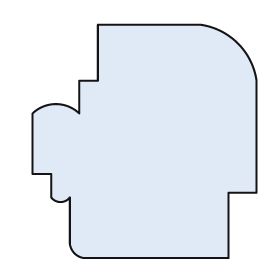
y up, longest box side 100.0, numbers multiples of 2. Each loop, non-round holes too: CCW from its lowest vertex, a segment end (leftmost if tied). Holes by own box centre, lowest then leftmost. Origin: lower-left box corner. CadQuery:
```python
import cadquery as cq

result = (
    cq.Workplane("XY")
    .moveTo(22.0, 0.0)
    .lineTo(84.0, 0.0)
    .lineTo(84.0, 28.0)
    .lineTo(96.0, 28.0)
    .lineTo(96.0, 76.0)
    .threePointArc((88.0, 92.0), (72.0, 100.0))
    .lineTo(28.0, 100.0)
    .lineTo(28.0, 76.0)
    .lineTo(20.0, 76.0)
    .lineTo(20.0, 62.0)
    .threePointArc((10.0, 66.0), (0.0, 62.0))
    .lineTo(0.0, 36.0)
    .lineTo(8.0, 36.0)
    .lineTo(8.0, 26.0)
    .threePointArc((12.0, 24.0), (16.0, 26.0))
    .lineTo(16.0, 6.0)
    .threePointArc((18.0, 2.0), (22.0, 0.0))
    .close()
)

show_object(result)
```